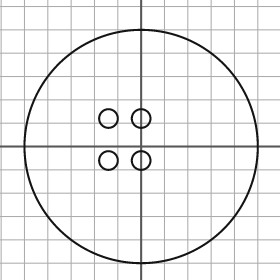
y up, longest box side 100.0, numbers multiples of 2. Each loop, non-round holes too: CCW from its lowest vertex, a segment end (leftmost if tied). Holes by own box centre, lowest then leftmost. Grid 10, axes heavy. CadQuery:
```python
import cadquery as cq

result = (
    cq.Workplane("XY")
    .moveTo(0.0, 0.0)
    .circle(50.0)
    .moveTo(-14.0, -6.0)
    .circle(4.0)
    .moveTo(0.0, -6.0)
    .circle(4.0)
    .moveTo(-14.0, 12.0)
    .circle(4.0)
    .moveTo(0.0, 12.0)
    .circle(4.0)
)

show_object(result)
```